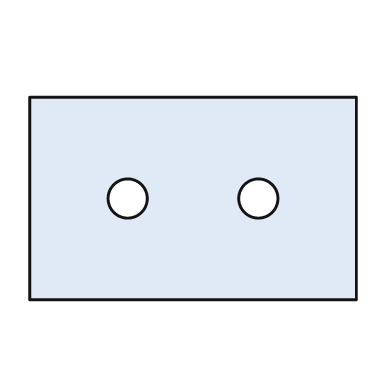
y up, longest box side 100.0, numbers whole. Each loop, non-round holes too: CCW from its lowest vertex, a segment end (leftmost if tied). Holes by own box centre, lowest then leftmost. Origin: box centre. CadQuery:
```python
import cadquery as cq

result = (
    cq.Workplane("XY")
    .moveTo(-50.0, -31.0)
    .lineTo(50.0, -31.0)
    .lineTo(50.0, 31.0)
    .lineTo(-50.0, 31.0)
    .close()
    .moveTo(-20.0, 0.0)
    .circle(6.0)
    .moveTo(20.0, 0.0)
    .circle(6.0)
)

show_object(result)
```